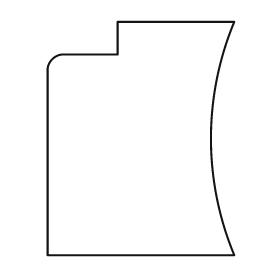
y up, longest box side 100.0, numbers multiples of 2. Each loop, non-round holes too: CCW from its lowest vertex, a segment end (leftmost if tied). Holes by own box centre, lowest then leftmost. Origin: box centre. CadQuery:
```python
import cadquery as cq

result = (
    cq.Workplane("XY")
    .moveTo(-40.0, -50.0)
    .lineTo(40.0, -50.0)
    .threePointArc((30.0, 0.0), (40.0, 50.0))
    .lineTo(-10.0, 50.0)
    .lineTo(-10.0, 36.0)
    .lineTo(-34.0, 36.0)
    .threePointArc((-38.0, 34.0), (-40.0, 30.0))
    .close()
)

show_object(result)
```